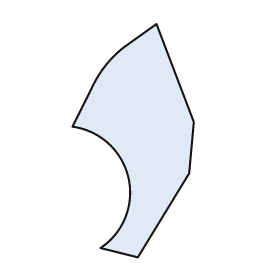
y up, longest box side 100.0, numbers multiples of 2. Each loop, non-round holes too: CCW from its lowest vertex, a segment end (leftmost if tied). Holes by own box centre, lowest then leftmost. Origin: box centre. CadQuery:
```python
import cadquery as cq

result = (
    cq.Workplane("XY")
    .moveTo(2.0, -50.0)
    .lineTo(24.0, -14.0)
    .lineTo(26.0, 8.0)
    .lineTo(10.0, 50.0)
    .lineTo(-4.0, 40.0)
    .threePointArc((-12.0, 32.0), (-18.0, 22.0))
    .lineTo(-26.0, 6.0)
    .threePointArc((-2.0, -16.0), (-14.0, -46.0))
    .close()
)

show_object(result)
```